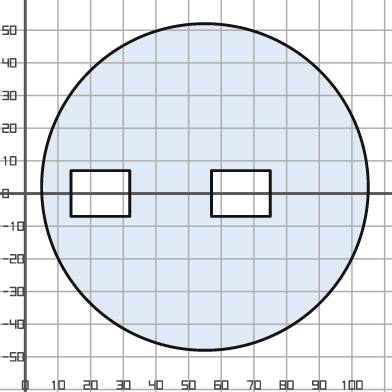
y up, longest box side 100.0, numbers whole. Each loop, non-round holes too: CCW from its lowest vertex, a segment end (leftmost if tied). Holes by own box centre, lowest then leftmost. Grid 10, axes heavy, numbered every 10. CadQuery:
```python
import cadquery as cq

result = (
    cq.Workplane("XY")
    .moveTo(55.0, 2.0)
    .circle(50.0)
    .moveTo(14.0, -7.0)
    .lineTo(32.0, -7.0)
    .lineTo(32.0, 7.0)
    .lineTo(14.0, 7.0)
    .close()
    .moveTo(57.0, -7.0)
    .lineTo(75.0, -7.0)
    .lineTo(75.0, 7.0)
    .lineTo(57.0, 7.0)
    .close()
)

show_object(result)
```